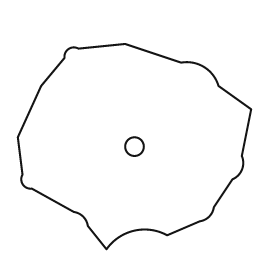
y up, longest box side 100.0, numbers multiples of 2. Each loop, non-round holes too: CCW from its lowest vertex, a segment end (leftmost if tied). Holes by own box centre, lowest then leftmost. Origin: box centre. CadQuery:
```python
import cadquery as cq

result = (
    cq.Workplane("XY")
    .moveTo(-12.0, -44.0)
    .threePointArc((0.0, -36.0), (14.0, -38.0))
    .lineTo(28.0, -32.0)
    .threePointArc((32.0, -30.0), (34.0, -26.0))
    .lineTo(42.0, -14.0)
    .threePointArc((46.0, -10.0), (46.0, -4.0))
    .lineTo(50.0, 16.0)
    .lineTo(36.0, 26.0)
    .threePointArc((30.0, 34.0), (20.0, 36.0))
    .lineTo(-4.0, 44.0)
    .lineTo(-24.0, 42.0)
    .threePointArc((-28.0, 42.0), (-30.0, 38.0))
    .lineTo(-40.0, 26.0)
    .lineTo(-50.0, 4.0)
    .lineTo(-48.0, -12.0)
    .threePointArc((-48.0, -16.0), (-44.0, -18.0))
    .lineTo(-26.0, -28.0)
    .threePointArc((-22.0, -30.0), (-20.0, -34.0))
    .close()
    .moveTo(0.0, 0.0)
    .circle(4.0)
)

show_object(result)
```